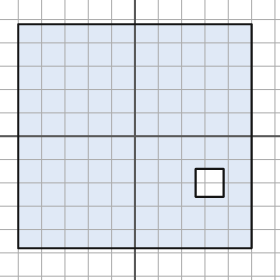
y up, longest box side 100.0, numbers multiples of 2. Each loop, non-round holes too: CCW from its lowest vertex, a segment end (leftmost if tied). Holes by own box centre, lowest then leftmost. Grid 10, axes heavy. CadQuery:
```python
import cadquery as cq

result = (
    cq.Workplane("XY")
    .moveTo(-50.0, -48.0)
    .lineTo(50.0, -48.0)
    .lineTo(50.0, 48.0)
    .lineTo(-50.0, 48.0)
    .close()
    .moveTo(26.0, -26.0)
    .lineTo(38.0, -26.0)
    .lineTo(38.0, -14.0)
    .lineTo(26.0, -14.0)
    .close()
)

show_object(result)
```